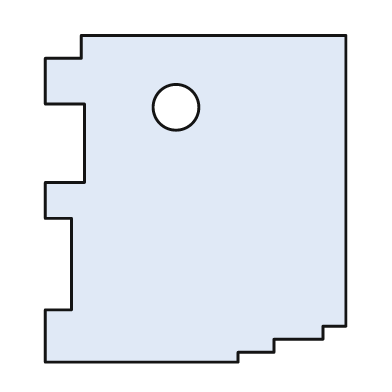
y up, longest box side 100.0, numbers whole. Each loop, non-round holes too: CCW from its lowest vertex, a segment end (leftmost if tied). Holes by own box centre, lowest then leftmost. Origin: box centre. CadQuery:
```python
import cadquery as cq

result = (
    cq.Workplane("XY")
    .moveTo(-46.0, -50.0)
    .lineTo(13.0, -50.0)
    .lineTo(13.0, -47.0)
    .lineTo(24.0, -47.0)
    .lineTo(24.0, -43.0)
    .lineTo(39.0, -43.0)
    .lineTo(39.0, -39.0)
    .lineTo(46.0, -39.0)
    .lineTo(46.0, 50.0)
    .lineTo(-35.0, 50.0)
    .lineTo(-35.0, 43.0)
    .lineTo(-46.0, 43.0)
    .lineTo(-46.0, 29.0)
    .lineTo(-34.0, 29.0)
    .lineTo(-34.0, 5.0)
    .lineTo(-46.0, 5.0)
    .lineTo(-46.0, -6.0)
    .lineTo(-38.0, -6.0)
    .lineTo(-38.0, -34.0)
    .lineTo(-46.0, -34.0)
    .close()
    .moveTo(-6.0, 28.0)
    .circle(7.0)
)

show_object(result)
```